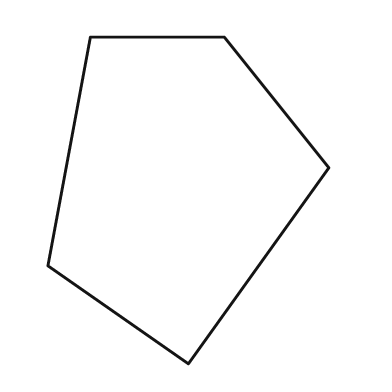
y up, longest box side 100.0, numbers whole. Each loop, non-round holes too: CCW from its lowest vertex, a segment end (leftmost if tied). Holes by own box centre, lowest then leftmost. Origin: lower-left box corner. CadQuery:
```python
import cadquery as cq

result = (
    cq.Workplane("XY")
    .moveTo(43.0, 0.0)
    .lineTo(86.0, 60.0)
    .lineTo(54.0, 100.0)
    .lineTo(13.0, 100.0)
    .lineTo(0.0, 30.0)
    .close()
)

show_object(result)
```